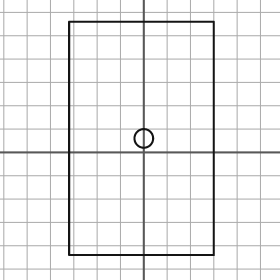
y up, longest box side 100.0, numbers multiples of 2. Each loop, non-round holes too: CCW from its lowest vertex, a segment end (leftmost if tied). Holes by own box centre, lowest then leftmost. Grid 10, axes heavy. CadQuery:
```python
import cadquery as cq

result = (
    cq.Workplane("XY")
    .moveTo(-32.0, -44.0)
    .lineTo(30.0, -44.0)
    .lineTo(30.0, 56.0)
    .lineTo(-32.0, 56.0)
    .close()
    .moveTo(0.0, 6.0)
    .circle(4.0)
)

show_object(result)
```